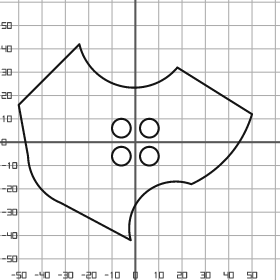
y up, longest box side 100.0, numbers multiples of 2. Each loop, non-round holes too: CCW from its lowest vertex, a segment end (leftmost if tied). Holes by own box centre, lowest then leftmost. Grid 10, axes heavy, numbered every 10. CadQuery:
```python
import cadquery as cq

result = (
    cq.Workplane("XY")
    .moveTo(-2.0, -42.0)
    .threePointArc((4.0, -22.0), (24.0, -18.0))
    .threePointArc((40.0, -6.0), (50.0, 12.0))
    .lineTo(18.0, 32.0)
    .threePointArc((-6.0, 24.0), (-24.0, 42.0))
    .lineTo(-50.0, 16.0)
    .lineTo(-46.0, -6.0)
    .threePointArc((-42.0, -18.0), (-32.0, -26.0))
    .close()
    .moveTo(-6.0, -6.0)
    .circle(4.0)
    .moveTo(6.0, -6.0)
    .circle(4.0)
    .moveTo(-6.0, 6.0)
    .circle(4.0)
    .moveTo(6.0, 6.0)
    .circle(4.0)
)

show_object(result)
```